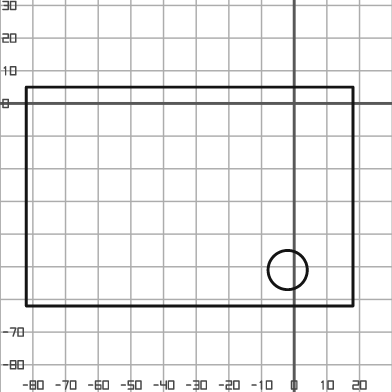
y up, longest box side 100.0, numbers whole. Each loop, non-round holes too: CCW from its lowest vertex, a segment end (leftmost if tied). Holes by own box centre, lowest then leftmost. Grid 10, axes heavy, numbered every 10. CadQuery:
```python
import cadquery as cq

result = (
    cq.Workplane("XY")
    .moveTo(-82.0, -62.0)
    .lineTo(18.0, -62.0)
    .lineTo(18.0, 5.0)
    .lineTo(-82.0, 5.0)
    .close()
    .moveTo(-2.0, -51.0)
    .circle(6.0)
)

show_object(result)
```